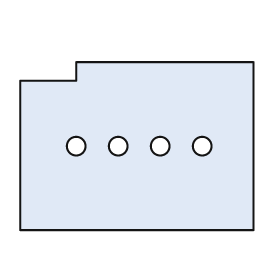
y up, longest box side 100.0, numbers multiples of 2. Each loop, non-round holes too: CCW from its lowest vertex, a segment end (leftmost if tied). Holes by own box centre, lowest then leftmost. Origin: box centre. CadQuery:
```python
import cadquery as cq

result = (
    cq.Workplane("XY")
    .moveTo(-50.0, -36.0)
    .lineTo(50.0, -36.0)
    .lineTo(50.0, 36.0)
    .lineTo(-26.0, 36.0)
    .lineTo(-26.0, 28.0)
    .lineTo(-50.0, 28.0)
    .close()
    .moveTo(-26.0, 0.0)
    .circle(4.0)
    .moveTo(-8.0, 0.0)
    .circle(4.0)
    .moveTo(10.0, 0.0)
    .circle(4.0)
    .moveTo(28.0, 0.0)
    .circle(4.0)
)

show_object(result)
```